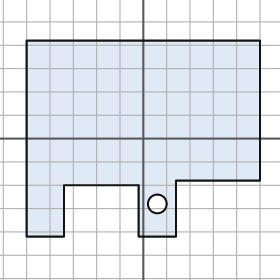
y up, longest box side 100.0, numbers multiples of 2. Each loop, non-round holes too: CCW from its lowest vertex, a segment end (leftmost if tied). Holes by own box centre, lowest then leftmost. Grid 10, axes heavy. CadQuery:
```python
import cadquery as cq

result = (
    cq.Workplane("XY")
    .moveTo(-50.0, -42.0)
    .lineTo(-34.0, -42.0)
    .lineTo(-34.0, -20.0)
    .lineTo(-2.0, -20.0)
    .lineTo(-2.0, -42.0)
    .lineTo(14.0, -42.0)
    .lineTo(14.0, -18.0)
    .lineTo(50.0, -18.0)
    .lineTo(50.0, 42.0)
    .lineTo(-50.0, 42.0)
    .close()
    .moveTo(6.0, -28.0)
    .circle(4.0)
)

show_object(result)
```